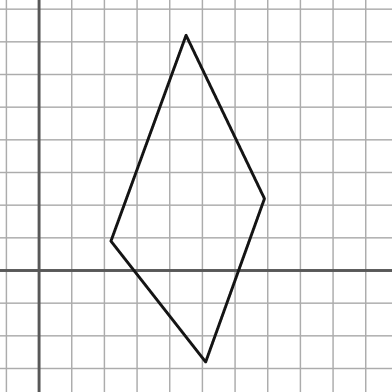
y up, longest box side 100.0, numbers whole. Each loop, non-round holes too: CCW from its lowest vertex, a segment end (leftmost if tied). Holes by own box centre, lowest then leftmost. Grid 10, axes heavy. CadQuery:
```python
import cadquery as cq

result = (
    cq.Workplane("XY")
    .moveTo(51.0, -28.0)
    .lineTo(69.0, 22.0)
    .lineTo(45.0, 72.0)
    .lineTo(22.0, 9.0)
    .close()
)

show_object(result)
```